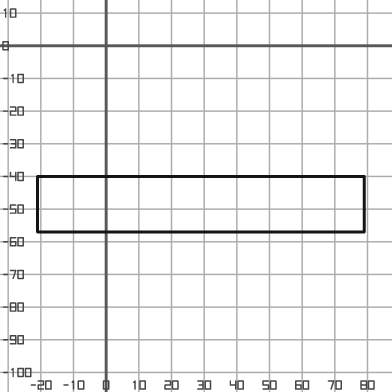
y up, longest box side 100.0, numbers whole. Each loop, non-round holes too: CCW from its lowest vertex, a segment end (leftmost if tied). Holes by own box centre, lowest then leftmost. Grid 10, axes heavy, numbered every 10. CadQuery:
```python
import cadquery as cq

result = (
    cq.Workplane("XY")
    .moveTo(-21.0, -57.0)
    .lineTo(79.0, -57.0)
    .lineTo(79.0, -40.0)
    .lineTo(-21.0, -40.0)
    .close()
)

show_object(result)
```